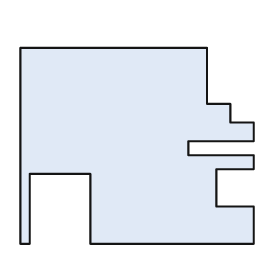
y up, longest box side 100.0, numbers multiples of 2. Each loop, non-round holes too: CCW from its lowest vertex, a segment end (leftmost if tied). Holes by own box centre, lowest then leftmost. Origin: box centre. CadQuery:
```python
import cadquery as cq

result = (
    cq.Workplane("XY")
    .moveTo(-50.0, -42.0)
    .lineTo(-46.0, -42.0)
    .lineTo(-46.0, -12.0)
    .lineTo(-20.0, -12.0)
    .lineTo(-20.0, -42.0)
    .lineTo(50.0, -42.0)
    .lineTo(50.0, -26.0)
    .lineTo(34.0, -26.0)
    .lineTo(34.0, -10.0)
    .lineTo(50.0, -10.0)
    .lineTo(50.0, -4.0)
    .lineTo(22.0, -4.0)
    .lineTo(22.0, 2.0)
    .lineTo(50.0, 2.0)
    .lineTo(50.0, 10.0)
    .lineTo(40.0, 10.0)
    .lineTo(40.0, 18.0)
    .lineTo(30.0, 18.0)
    .lineTo(30.0, 42.0)
    .lineTo(-50.0, 42.0)
    .close()
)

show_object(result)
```